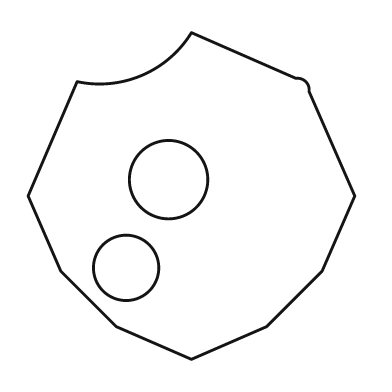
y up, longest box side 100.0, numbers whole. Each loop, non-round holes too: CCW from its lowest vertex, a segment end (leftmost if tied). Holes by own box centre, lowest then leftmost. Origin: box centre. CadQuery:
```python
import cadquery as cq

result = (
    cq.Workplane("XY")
    .moveTo(0.0, -50.0)
    .lineTo(23.0, -40.0)
    .lineTo(40.0, -23.0)
    .lineTo(50.0, 0.0)
    .lineTo(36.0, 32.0)
    .threePointArc((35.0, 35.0), (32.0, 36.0))
    .lineTo(0.0, 50.0)
    .threePointArc((-15.0, 37.0), (-35.0, 35.0))
    .lineTo(-50.0, 0.0)
    .lineTo(-40.0, -23.0)
    .lineTo(-23.0, -40.0)
    .close()
    .moveTo(-20.0, -22.0)
    .circle(10.0)
    .moveTo(-7.0, 5.0)
    .circle(12.0)
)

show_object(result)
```